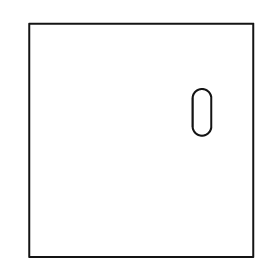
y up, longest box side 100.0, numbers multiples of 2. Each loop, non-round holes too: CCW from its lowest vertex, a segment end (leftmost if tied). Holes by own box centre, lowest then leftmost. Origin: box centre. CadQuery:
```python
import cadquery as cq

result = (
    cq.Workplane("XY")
    .moveTo(-48.0, -50.0)
    .lineTo(48.0, -50.0)
    .lineTo(48.0, 50.0)
    .lineTo(-48.0, 50.0)
    .close()
    .moveTo(22.0, 6.0)
    .threePointArc((26.0, 2.0), (30.0, 6.0))
    .lineTo(30.0, 18.0)
    .threePointArc((26.0, 22.0), (22.0, 18.0))
    .close()
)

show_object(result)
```